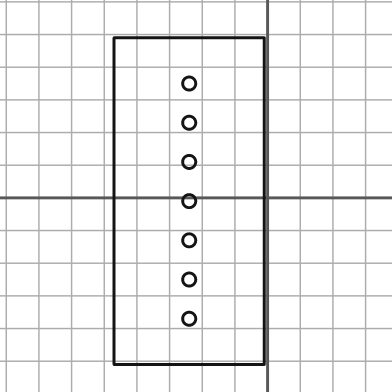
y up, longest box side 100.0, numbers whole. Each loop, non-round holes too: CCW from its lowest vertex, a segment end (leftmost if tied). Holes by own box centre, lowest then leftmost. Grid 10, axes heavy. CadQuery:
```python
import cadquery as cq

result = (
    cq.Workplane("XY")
    .moveTo(-47.0, -51.0)
    .lineTo(-1.0, -51.0)
    .lineTo(-1.0, 49.0)
    .lineTo(-47.0, 49.0)
    .close()
    .moveTo(-24.0, -37.0)
    .circle(2.0)
    .moveTo(-24.0, -25.0)
    .circle(2.0)
    .moveTo(-24.0, -13.0)
    .circle(2.0)
    .moveTo(-24.0, -1.0)
    .circle(2.0)
    .moveTo(-24.0, 11.0)
    .circle(2.0)
    .moveTo(-24.0, 23.0)
    .circle(2.0)
    .moveTo(-24.0, 35.0)
    .circle(2.0)
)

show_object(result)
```